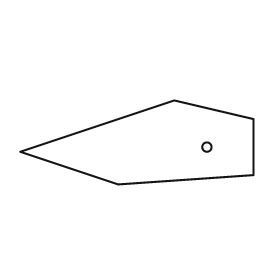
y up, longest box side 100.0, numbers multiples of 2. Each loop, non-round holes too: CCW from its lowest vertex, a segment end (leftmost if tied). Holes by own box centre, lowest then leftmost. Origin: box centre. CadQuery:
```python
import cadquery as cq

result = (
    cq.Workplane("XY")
    .moveTo(-8.0, -18.0)
    .lineTo(50.0, -14.0)
    .lineTo(50.0, 10.0)
    .lineTo(16.0, 18.0)
    .lineTo(-50.0, -4.0)
    .close()
    .moveTo(30.0, -2.0)
    .circle(2.0)
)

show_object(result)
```